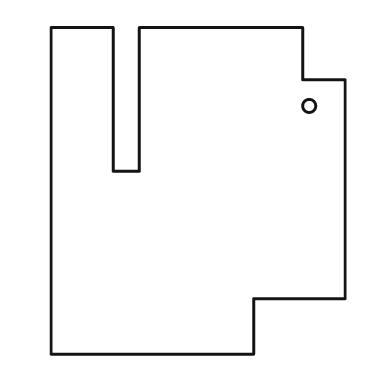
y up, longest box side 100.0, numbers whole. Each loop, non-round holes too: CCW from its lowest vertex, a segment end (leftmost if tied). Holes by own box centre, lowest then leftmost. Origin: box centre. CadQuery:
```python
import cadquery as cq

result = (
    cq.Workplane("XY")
    .moveTo(-45.0, -50.0)
    .lineTo(17.0, -50.0)
    .lineTo(17.0, -33.0)
    .lineTo(45.0, -33.0)
    .lineTo(45.0, 34.0)
    .lineTo(32.0, 34.0)
    .lineTo(32.0, 50.0)
    .lineTo(-18.0, 50.0)
    .lineTo(-18.0, 6.0)
    .lineTo(-26.0, 6.0)
    .lineTo(-26.0, 50.0)
    .lineTo(-45.0, 50.0)
    .close()
    .moveTo(34.0, 26.0)
    .circle(2.0)
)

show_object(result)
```